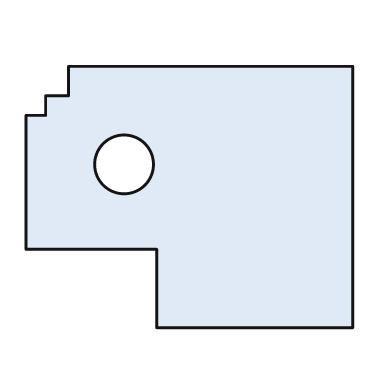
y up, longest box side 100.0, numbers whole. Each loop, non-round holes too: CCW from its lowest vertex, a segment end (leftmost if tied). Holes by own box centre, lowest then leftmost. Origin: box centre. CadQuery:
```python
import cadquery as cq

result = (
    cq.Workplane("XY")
    .moveTo(-10.0, -40.0)
    .lineTo(50.0, -40.0)
    .lineTo(50.0, 40.0)
    .lineTo(-37.0, 40.0)
    .lineTo(-37.0, 31.0)
    .lineTo(-44.0, 31.0)
    .lineTo(-44.0, 25.0)
    .lineTo(-50.0, 25.0)
    .lineTo(-50.0, -16.0)
    .lineTo(-10.0, -16.0)
    .close()
    .moveTo(-20.0, 10.0)
    .circle(9.0)
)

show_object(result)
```